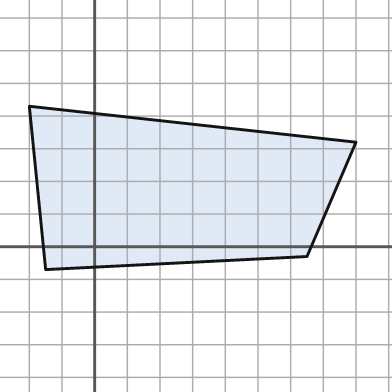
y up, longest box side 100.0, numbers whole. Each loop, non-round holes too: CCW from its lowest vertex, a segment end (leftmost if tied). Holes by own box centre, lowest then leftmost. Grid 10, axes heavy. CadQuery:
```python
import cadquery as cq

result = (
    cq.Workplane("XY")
    .moveTo(-15.0, -7.0)
    .lineTo(65.0, -3.0)
    .lineTo(80.0, 32.0)
    .lineTo(-20.0, 43.0)
    .close()
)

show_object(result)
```